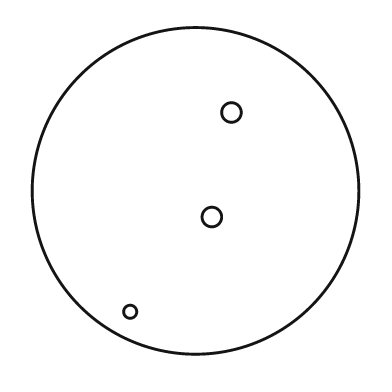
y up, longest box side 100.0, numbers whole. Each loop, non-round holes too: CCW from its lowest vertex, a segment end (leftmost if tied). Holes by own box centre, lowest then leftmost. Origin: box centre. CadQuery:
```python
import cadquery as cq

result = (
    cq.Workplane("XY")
    .moveTo(0.0, 0.0)
    .circle(50.0)
    .moveTo(-20.0, -37.0)
    .circle(2.0)
    .moveTo(5.0, -8.0)
    .circle(3.0)
    .moveTo(11.0, 24.0)
    .circle(3.0)
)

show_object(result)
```